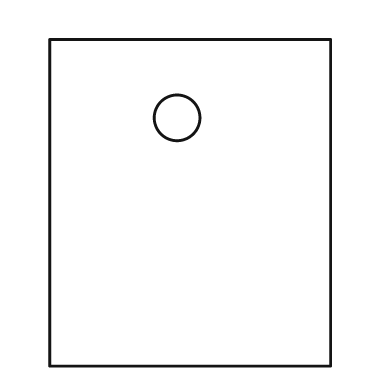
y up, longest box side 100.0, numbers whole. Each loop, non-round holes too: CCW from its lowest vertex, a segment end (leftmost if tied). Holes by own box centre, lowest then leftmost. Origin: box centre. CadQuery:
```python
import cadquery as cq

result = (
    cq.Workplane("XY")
    .moveTo(-43.0, -50.0)
    .lineTo(43.0, -50.0)
    .lineTo(43.0, 50.0)
    .lineTo(-43.0, 50.0)
    .close()
    .moveTo(-4.0, 26.0)
    .circle(7.0)
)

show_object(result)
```